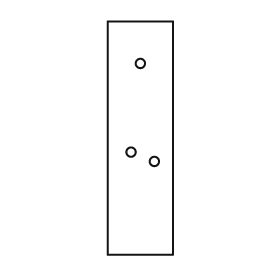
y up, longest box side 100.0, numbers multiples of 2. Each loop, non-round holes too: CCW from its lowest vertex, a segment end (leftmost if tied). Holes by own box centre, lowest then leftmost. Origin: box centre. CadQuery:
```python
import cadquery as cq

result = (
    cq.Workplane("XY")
    .moveTo(-14.0, -50.0)
    .lineTo(14.0, -50.0)
    .lineTo(14.0, 50.0)
    .lineTo(-14.0, 50.0)
    .close()
    .moveTo(6.0, -10.0)
    .circle(2.0)
    .moveTo(-4.0, -6.0)
    .circle(2.0)
    .moveTo(0.0, 32.0)
    .circle(2.0)
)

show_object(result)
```